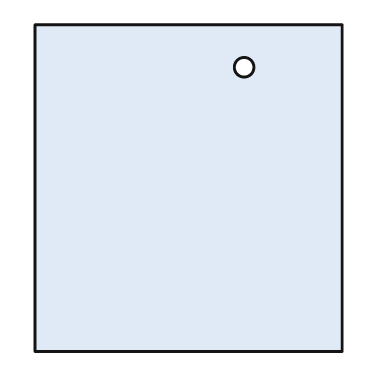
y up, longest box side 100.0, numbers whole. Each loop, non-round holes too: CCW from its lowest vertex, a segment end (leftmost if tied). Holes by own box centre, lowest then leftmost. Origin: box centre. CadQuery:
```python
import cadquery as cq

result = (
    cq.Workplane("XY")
    .moveTo(-47.0, -50.0)
    .lineTo(47.0, -50.0)
    .lineTo(47.0, 50.0)
    .lineTo(-47.0, 50.0)
    .close()
    .moveTo(17.0, 37.0)
    .circle(3.0)
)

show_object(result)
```